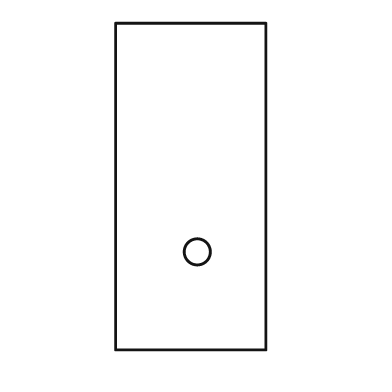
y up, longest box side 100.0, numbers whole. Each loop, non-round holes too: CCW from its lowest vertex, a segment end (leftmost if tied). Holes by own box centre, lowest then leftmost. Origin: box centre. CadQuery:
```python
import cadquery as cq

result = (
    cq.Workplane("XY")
    .moveTo(-23.0, -50.0)
    .lineTo(23.0, -50.0)
    .lineTo(23.0, 50.0)
    .lineTo(-23.0, 50.0)
    .close()
    .moveTo(2.0, -20.0)
    .circle(4.0)
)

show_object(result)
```